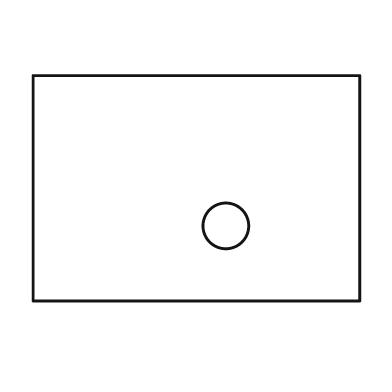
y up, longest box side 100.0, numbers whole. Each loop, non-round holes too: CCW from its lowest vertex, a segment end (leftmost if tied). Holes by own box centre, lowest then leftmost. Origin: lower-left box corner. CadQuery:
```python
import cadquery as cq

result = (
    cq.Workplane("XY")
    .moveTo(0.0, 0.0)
    .lineTo(100.0, 0.0)
    .lineTo(100.0, 69.0)
    .lineTo(0.0, 69.0)
    .close()
    .moveTo(59.0, 23.0)
    .circle(7.0)
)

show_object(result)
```